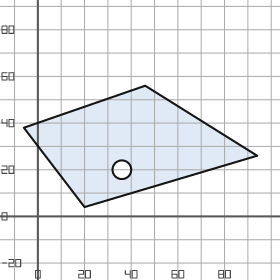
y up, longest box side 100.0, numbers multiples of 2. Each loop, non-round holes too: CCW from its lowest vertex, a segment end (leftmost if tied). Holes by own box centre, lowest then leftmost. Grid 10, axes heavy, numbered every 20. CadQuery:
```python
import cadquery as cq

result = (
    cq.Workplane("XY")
    .moveTo(20.0, 4.0)
    .lineTo(94.0, 26.0)
    .lineTo(46.0, 56.0)
    .lineTo(-6.0, 38.0)
    .close()
    .moveTo(36.0, 20.0)
    .circle(4.0)
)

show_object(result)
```